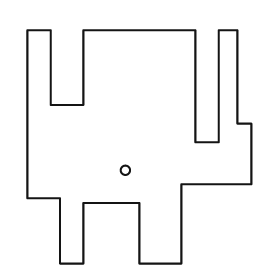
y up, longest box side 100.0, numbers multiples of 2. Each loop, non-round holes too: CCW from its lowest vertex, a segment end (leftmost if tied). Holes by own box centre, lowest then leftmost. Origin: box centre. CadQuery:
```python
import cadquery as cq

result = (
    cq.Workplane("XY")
    .moveTo(-34.0, -50.0)
    .lineTo(-24.0, -50.0)
    .lineTo(-24.0, -24.0)
    .lineTo(0.0, -24.0)
    .lineTo(0.0, -50.0)
    .lineTo(18.0, -50.0)
    .lineTo(18.0, -16.0)
    .lineTo(48.0, -16.0)
    .lineTo(48.0, 10.0)
    .lineTo(42.0, 10.0)
    .lineTo(42.0, 50.0)
    .lineTo(34.0, 50.0)
    .lineTo(34.0, 2.0)
    .lineTo(24.0, 2.0)
    .lineTo(24.0, 50.0)
    .lineTo(-24.0, 50.0)
    .lineTo(-24.0, 18.0)
    .lineTo(-38.0, 18.0)
    .lineTo(-38.0, 50.0)
    .lineTo(-48.0, 50.0)
    .lineTo(-48.0, -22.0)
    .lineTo(-34.0, -22.0)
    .close()
    .moveTo(-6.0, -10.0)
    .circle(2.0)
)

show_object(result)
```